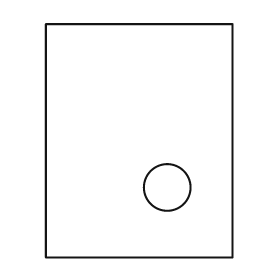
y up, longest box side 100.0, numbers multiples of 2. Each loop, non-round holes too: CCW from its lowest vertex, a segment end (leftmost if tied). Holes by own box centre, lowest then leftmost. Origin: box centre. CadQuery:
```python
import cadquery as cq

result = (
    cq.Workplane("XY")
    .moveTo(-40.0, -50.0)
    .lineTo(40.0, -50.0)
    .lineTo(40.0, 50.0)
    .lineTo(-40.0, 50.0)
    .close()
    .moveTo(12.0, -20.0)
    .circle(10.0)
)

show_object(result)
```